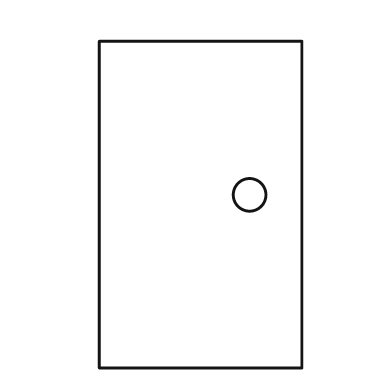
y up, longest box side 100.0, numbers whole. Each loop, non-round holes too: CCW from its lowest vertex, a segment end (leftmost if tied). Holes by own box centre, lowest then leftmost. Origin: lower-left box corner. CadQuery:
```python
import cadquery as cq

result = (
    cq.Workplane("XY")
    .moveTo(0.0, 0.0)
    .lineTo(62.0, 0.0)
    .lineTo(62.0, 100.0)
    .lineTo(0.0, 100.0)
    .close()
    .moveTo(46.0, 53.0)
    .circle(5.0)
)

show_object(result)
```